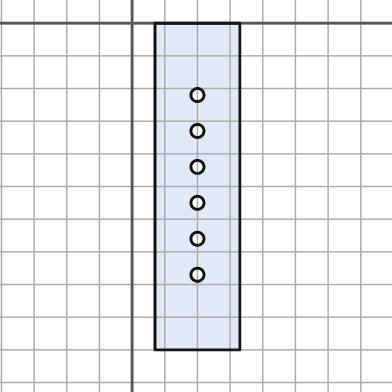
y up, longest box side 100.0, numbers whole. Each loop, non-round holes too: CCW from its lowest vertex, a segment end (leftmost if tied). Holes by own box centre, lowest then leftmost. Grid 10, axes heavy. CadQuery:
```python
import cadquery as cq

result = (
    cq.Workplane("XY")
    .moveTo(7.0, -100.0)
    .lineTo(33.0, -100.0)
    .lineTo(33.0, 0.0)
    .lineTo(7.0, 0.0)
    .close()
    .moveTo(20.0, -77.0)
    .circle(2.0)
    .moveTo(20.0, -66.0)
    .circle(2.0)
    .moveTo(20.0, -55.0)
    .circle(2.0)
    .moveTo(20.0, -44.0)
    .circle(2.0)
    .moveTo(20.0, -33.0)
    .circle(2.0)
    .moveTo(20.0, -22.0)
    .circle(2.0)
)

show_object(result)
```